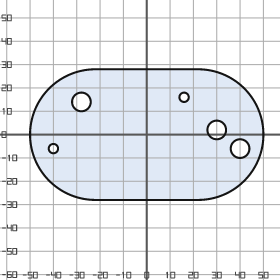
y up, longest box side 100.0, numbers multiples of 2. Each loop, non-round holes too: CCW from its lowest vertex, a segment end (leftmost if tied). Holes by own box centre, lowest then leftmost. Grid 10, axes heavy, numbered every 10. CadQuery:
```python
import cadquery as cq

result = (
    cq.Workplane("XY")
    .moveTo(-22.0, -28.0)
    .lineTo(22.0, -28.0)
    .threePointArc((50.0, 0.0), (22.0, 28.0))
    .lineTo(-22.0, 28.0)
    .threePointArc((-50.0, 0.0), (-22.0, -28.0))
    .close()
    .moveTo(-40.0, -6.0)
    .circle(2.0)
    .moveTo(40.0, -6.0)
    .circle(4.0)
    .moveTo(30.0, 2.0)
    .circle(4.0)
    .moveTo(-28.0, 14.0)
    .circle(4.0)
    .moveTo(16.0, 16.0)
    .circle(2.0)
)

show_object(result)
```